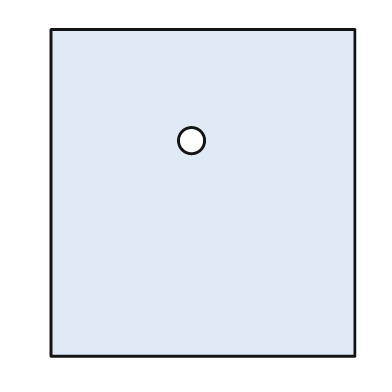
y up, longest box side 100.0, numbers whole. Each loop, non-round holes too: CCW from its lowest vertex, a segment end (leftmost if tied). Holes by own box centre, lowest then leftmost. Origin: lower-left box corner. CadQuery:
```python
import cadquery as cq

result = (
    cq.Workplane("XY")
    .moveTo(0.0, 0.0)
    .lineTo(93.0, 0.0)
    .lineTo(93.0, 100.0)
    .lineTo(0.0, 100.0)
    .close()
    .moveTo(43.0, 66.0)
    .circle(4.0)
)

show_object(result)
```